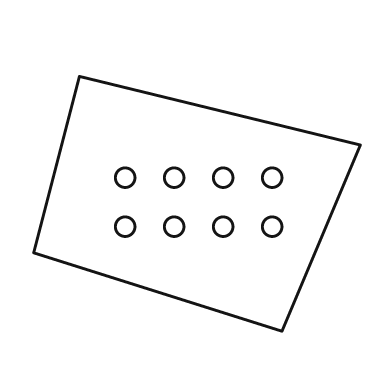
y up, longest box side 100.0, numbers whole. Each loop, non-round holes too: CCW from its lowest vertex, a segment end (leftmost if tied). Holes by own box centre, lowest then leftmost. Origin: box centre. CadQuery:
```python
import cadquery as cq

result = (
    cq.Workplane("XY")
    .moveTo(26.0, -39.0)
    .lineTo(50.0, 18.0)
    .lineTo(-36.0, 39.0)
    .lineTo(-50.0, -15.0)
    .close()
    .moveTo(-22.0, -7.0)
    .circle(3.0)
    .moveTo(-7.0, -7.0)
    .circle(3.0)
    .moveTo(8.0, -7.0)
    .circle(3.0)
    .moveTo(23.0, -7.0)
    .circle(3.0)
    .moveTo(-22.0, 8.0)
    .circle(3.0)
    .moveTo(-7.0, 8.0)
    .circle(3.0)
    .moveTo(8.0, 8.0)
    .circle(3.0)
    .moveTo(23.0, 8.0)
    .circle(3.0)
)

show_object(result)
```